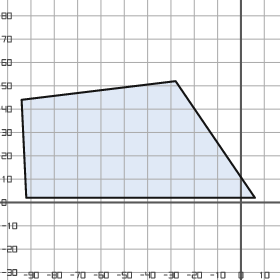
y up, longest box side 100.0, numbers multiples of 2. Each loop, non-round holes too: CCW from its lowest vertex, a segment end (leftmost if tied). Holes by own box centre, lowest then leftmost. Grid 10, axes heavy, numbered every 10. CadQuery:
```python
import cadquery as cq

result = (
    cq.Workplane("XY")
    .moveTo(-92.0, 2.0)
    .lineTo(6.0, 2.0)
    .lineTo(-28.0, 52.0)
    .lineTo(-94.0, 44.0)
    .close()
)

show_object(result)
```